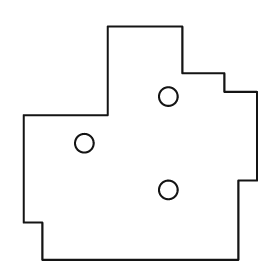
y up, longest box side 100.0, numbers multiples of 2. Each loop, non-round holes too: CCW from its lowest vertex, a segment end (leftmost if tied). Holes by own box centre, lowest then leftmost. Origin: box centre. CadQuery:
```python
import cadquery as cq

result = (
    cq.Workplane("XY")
    .moveTo(-42.0, -50.0)
    .lineTo(42.0, -50.0)
    .lineTo(42.0, -16.0)
    .lineTo(50.0, -16.0)
    .lineTo(50.0, 22.0)
    .lineTo(36.0, 22.0)
    .lineTo(36.0, 30.0)
    .lineTo(18.0, 30.0)
    .lineTo(18.0, 50.0)
    .lineTo(-14.0, 50.0)
    .lineTo(-14.0, 12.0)
    .lineTo(-50.0, 12.0)
    .lineTo(-50.0, -34.0)
    .lineTo(-42.0, -34.0)
    .close()
    .moveTo(12.0, -20.0)
    .circle(4.0)
    .moveTo(-24.0, 0.0)
    .circle(4.0)
    .moveTo(12.0, 20.0)
    .circle(4.0)
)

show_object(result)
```